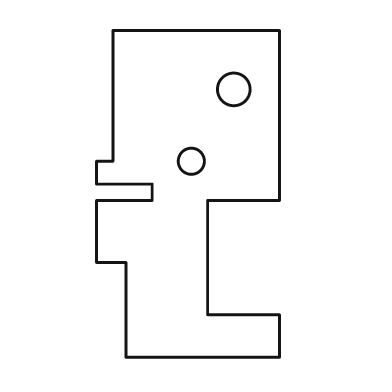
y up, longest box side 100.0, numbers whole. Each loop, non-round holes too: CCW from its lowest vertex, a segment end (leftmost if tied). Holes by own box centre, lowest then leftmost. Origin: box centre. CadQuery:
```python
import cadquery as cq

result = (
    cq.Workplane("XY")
    .moveTo(-19.0, -50.0)
    .lineTo(28.0, -50.0)
    .lineTo(28.0, -37.0)
    .lineTo(6.0, -37.0)
    .lineTo(6.0, -2.0)
    .lineTo(28.0, -2.0)
    .lineTo(28.0, 50.0)
    .lineTo(-23.0, 50.0)
    .lineTo(-23.0, 10.0)
    .lineTo(-28.0, 10.0)
    .lineTo(-28.0, 3.0)
    .lineTo(-11.0, 3.0)
    .lineTo(-11.0, -2.0)
    .lineTo(-28.0, -2.0)
    .lineTo(-28.0, -21.0)
    .lineTo(-19.0, -21.0)
    .close()
    .moveTo(1.0, 10.0)
    .circle(4.0)
    .moveTo(14.0, 32.0)
    .circle(5.0)
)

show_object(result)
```